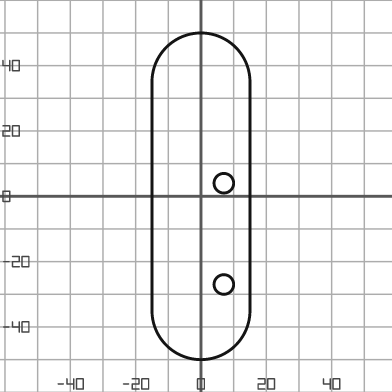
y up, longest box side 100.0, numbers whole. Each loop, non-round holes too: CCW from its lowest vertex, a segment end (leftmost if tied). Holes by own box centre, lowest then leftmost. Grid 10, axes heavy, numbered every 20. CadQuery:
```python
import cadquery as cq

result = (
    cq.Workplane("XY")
    .moveTo(-15.0, -35.0)
    .threePointArc((0.0, -50.0), (15.0, -35.0))
    .lineTo(15.0, 35.0)
    .threePointArc((0.0, 50.0), (-15.0, 35.0))
    .close()
    .moveTo(7.0, -27.0)
    .circle(3.0)
    .moveTo(7.0, 4.0)
    .circle(3.0)
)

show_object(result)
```